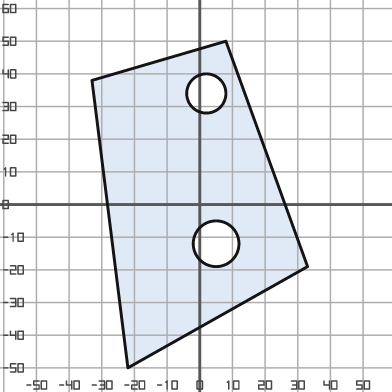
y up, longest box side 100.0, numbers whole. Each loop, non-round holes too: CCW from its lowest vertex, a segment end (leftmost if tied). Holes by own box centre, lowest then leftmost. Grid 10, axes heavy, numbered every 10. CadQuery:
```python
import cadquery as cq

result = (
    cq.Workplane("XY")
    .moveTo(-22.0, -50.0)
    .lineTo(33.0, -19.0)
    .lineTo(8.0, 50.0)
    .lineTo(-33.0, 38.0)
    .close()
    .moveTo(5.0, -12.0)
    .circle(7.0)
    .moveTo(2.0, 34.0)
    .circle(6.0)
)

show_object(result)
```